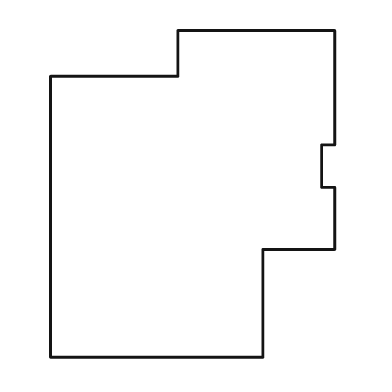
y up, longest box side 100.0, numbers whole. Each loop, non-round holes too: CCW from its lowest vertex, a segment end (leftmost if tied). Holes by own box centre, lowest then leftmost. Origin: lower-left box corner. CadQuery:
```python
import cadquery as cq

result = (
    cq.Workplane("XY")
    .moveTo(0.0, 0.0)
    .lineTo(65.0, 0.0)
    .lineTo(65.0, 33.0)
    .lineTo(87.0, 33.0)
    .lineTo(87.0, 52.0)
    .lineTo(83.0, 52.0)
    .lineTo(83.0, 65.0)
    .lineTo(87.0, 65.0)
    .lineTo(87.0, 100.0)
    .lineTo(39.0, 100.0)
    .lineTo(39.0, 86.0)
    .lineTo(0.0, 86.0)
    .close()
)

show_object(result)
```